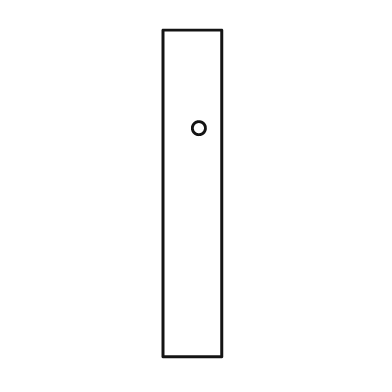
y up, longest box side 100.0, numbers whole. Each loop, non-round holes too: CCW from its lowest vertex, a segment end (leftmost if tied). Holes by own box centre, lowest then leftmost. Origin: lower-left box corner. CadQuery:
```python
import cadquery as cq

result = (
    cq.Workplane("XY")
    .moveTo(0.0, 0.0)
    .lineTo(18.0, 0.0)
    .lineTo(18.0, 100.0)
    .lineTo(0.0, 100.0)
    .close()
    .moveTo(11.0, 70.0)
    .circle(2.0)
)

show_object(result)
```